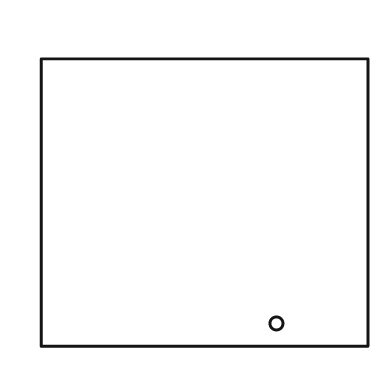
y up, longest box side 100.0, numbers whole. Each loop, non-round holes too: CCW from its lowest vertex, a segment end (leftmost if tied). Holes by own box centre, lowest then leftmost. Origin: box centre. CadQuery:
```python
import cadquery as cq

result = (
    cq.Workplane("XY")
    .moveTo(-50.0, -44.0)
    .lineTo(50.0, -44.0)
    .lineTo(50.0, 44.0)
    .lineTo(-50.0, 44.0)
    .close()
    .moveTo(22.0, -37.0)
    .circle(2.0)
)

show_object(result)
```